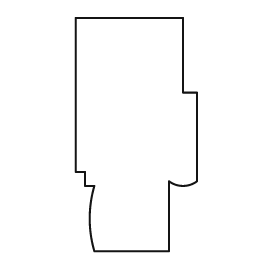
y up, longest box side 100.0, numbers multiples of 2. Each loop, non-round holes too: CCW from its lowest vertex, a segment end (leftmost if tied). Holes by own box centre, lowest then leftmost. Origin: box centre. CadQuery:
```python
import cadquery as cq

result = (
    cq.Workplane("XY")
    .moveTo(-18.0, -50.0)
    .lineTo(14.0, -50.0)
    .lineTo(14.0, -20.0)
    .threePointArc((20.0, -22.0), (26.0, -20.0))
    .lineTo(26.0, 18.0)
    .lineTo(20.0, 18.0)
    .lineTo(20.0, 50.0)
    .lineTo(-26.0, 50.0)
    .lineTo(-26.0, -16.0)
    .lineTo(-22.0, -16.0)
    .lineTo(-22.0, -22.0)
    .lineTo(-18.0, -22.0)
    .threePointArc((-20.0, -36.0), (-18.0, -50.0))
    .close()
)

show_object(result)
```